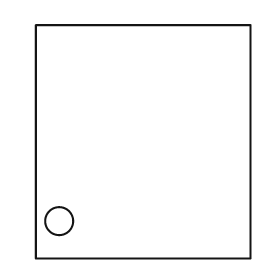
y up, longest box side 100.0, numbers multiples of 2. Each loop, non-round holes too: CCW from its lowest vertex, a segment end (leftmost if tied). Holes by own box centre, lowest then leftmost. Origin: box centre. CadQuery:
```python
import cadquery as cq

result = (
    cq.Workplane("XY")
    .moveTo(-46.0, -50.0)
    .lineTo(46.0, -50.0)
    .lineTo(46.0, 50.0)
    .lineTo(-46.0, 50.0)
    .close()
    .moveTo(-36.0, -34.0)
    .circle(6.0)
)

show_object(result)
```